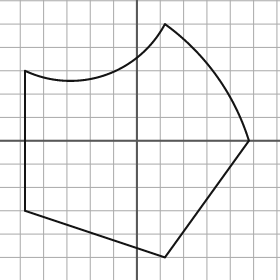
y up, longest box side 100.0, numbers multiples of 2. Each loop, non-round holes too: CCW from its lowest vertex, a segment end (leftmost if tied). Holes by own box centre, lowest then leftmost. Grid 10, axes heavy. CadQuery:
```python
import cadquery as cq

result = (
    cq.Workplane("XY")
    .moveTo(12.0, -50.0)
    .lineTo(48.0, 0.0)
    .threePointArc((34.0, 28.0), (12.0, 50.0))
    .threePointArc((-14.0, 28.0), (-48.0, 30.0))
    .lineTo(-48.0, -30.0)
    .close()
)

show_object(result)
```